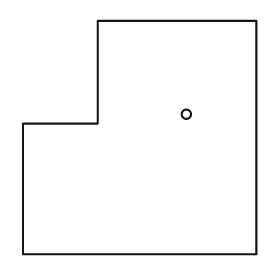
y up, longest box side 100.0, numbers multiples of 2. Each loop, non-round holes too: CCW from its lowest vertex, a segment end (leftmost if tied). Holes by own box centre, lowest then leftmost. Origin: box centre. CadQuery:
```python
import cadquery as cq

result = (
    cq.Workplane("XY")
    .moveTo(-50.0, -50.0)
    .lineTo(50.0, -50.0)
    .lineTo(50.0, 50.0)
    .lineTo(-18.0, 50.0)
    .lineTo(-18.0, 6.0)
    .lineTo(-50.0, 6.0)
    .close()
    .moveTo(20.0, 10.0)
    .circle(2.0)
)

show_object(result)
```